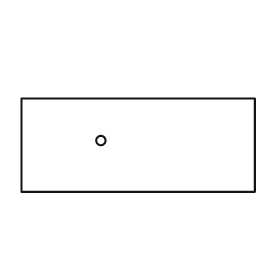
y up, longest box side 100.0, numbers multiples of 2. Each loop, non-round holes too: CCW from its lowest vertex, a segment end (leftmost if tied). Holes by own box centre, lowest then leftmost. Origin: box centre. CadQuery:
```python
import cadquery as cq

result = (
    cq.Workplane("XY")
    .moveTo(-50.0, -20.0)
    .lineTo(50.0, -20.0)
    .lineTo(50.0, 20.0)
    .lineTo(-50.0, 20.0)
    .close()
    .moveTo(-16.0, 2.0)
    .circle(2.0)
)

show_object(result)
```